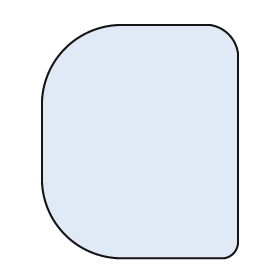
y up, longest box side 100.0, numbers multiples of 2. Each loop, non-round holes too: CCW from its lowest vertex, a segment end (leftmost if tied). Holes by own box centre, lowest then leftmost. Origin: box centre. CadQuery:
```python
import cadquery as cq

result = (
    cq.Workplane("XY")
    .moveTo(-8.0, -50.0)
    .lineTo(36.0, -50.0)
    .threePointArc((40.0, -48.0), (42.0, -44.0))
    .lineTo(42.0, 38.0)
    .threePointArc((38.0, 46.0), (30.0, 50.0))
    .lineTo(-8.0, 50.0)
    .threePointArc((-32.0, 40.0), (-42.0, 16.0))
    .lineTo(-42.0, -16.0)
    .threePointArc((-32.0, -40.0), (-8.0, -50.0))
    .close()
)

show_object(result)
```